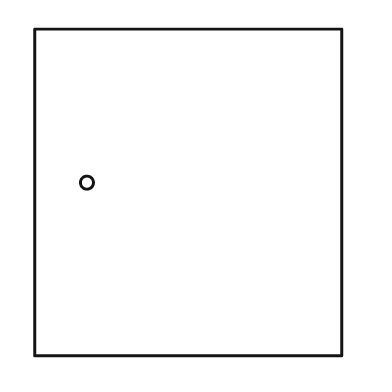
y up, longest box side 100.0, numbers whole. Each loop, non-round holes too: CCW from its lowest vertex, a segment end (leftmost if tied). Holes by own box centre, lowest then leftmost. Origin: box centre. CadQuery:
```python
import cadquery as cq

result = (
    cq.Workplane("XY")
    .moveTo(-47.0, -50.0)
    .lineTo(47.0, -50.0)
    .lineTo(47.0, 50.0)
    .lineTo(-47.0, 50.0)
    .close()
    .moveTo(-31.0, 3.0)
    .circle(2.0)
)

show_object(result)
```